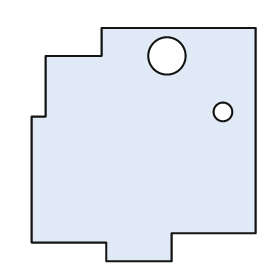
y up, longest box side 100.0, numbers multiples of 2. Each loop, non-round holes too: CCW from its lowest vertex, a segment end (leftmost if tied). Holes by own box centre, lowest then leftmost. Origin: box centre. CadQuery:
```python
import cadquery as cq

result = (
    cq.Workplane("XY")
    .moveTo(-16.0, -50.0)
    .lineTo(12.0, -50.0)
    .lineTo(12.0, -38.0)
    .lineTo(48.0, -38.0)
    .lineTo(48.0, 50.0)
    .lineTo(-18.0, 50.0)
    .lineTo(-18.0, 38.0)
    .lineTo(-42.0, 38.0)
    .lineTo(-42.0, 12.0)
    .lineTo(-48.0, 12.0)
    .lineTo(-48.0, -42.0)
    .lineTo(-16.0, -42.0)
    .close()
    .moveTo(34.0, 14.0)
    .circle(4.0)
    .moveTo(10.0, 38.0)
    .circle(8.0)
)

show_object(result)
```